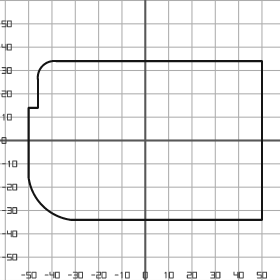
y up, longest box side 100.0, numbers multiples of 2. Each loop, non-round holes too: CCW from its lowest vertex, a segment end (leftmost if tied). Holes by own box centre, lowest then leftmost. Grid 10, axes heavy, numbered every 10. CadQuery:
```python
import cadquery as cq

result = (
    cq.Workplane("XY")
    .moveTo(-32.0, -34.0)
    .lineTo(50.0, -34.0)
    .lineTo(50.0, 34.0)
    .lineTo(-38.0, 34.0)
    .threePointArc((-44.0, 32.0), (-46.0, 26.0))
    .lineTo(-46.0, 14.0)
    .lineTo(-50.0, 14.0)
    .lineTo(-50.0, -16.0)
    .threePointArc((-44.0, -28.0), (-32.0, -34.0))
    .close()
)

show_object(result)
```